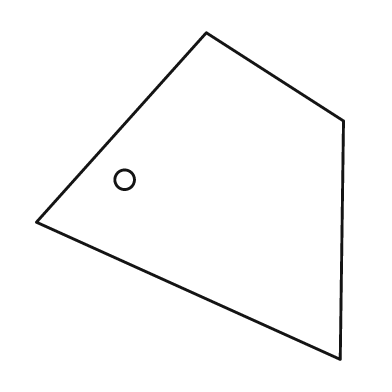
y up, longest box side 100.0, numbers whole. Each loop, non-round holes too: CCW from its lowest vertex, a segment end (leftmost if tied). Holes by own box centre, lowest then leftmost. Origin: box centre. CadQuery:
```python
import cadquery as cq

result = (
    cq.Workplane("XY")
    .moveTo(46.0, -50.0)
    .lineTo(47.0, 23.0)
    .lineTo(5.0, 50.0)
    .lineTo(-47.0, -8.0)
    .close()
    .moveTo(-20.0, 5.0)
    .circle(3.0)
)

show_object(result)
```